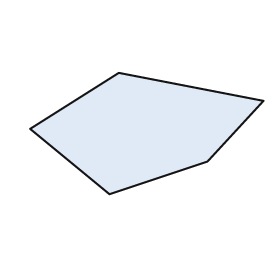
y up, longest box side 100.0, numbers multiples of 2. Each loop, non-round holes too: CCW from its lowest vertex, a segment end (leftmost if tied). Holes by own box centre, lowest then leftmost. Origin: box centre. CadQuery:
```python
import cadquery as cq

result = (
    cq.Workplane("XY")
    .moveTo(-16.0, -26.0)
    .lineTo(26.0, -12.0)
    .lineTo(50.0, 14.0)
    .lineTo(-12.0, 26.0)
    .lineTo(-50.0, 2.0)
    .close()
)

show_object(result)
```